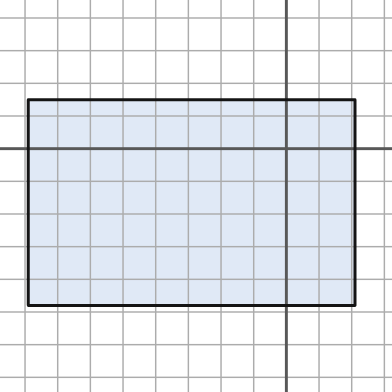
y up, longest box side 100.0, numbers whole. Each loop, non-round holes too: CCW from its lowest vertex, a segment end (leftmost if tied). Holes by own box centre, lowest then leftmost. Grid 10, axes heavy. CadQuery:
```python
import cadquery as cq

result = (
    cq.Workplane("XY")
    .moveTo(-79.0, -48.0)
    .lineTo(21.0, -48.0)
    .lineTo(21.0, 15.0)
    .lineTo(-79.0, 15.0)
    .close()
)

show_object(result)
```